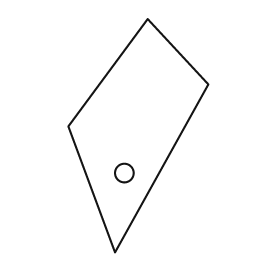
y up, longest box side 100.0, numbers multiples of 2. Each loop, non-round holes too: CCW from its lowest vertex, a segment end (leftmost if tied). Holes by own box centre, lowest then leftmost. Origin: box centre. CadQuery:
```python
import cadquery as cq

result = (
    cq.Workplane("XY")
    .moveTo(-10.0, -50.0)
    .lineTo(30.0, 22.0)
    .lineTo(4.0, 50.0)
    .lineTo(-30.0, 4.0)
    .close()
    .moveTo(-6.0, -16.0)
    .circle(4.0)
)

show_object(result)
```